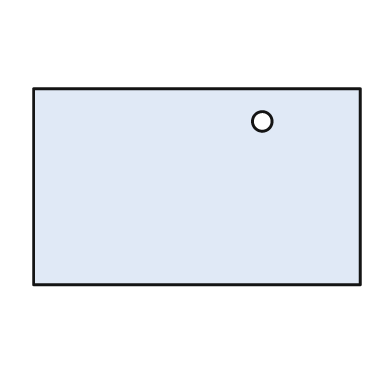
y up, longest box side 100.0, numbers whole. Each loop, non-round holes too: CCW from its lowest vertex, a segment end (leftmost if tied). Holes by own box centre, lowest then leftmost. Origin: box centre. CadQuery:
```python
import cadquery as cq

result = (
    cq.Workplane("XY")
    .moveTo(-50.0, -30.0)
    .lineTo(50.0, -30.0)
    .lineTo(50.0, 30.0)
    .lineTo(-50.0, 30.0)
    .close()
    .moveTo(20.0, 20.0)
    .circle(3.0)
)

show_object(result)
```